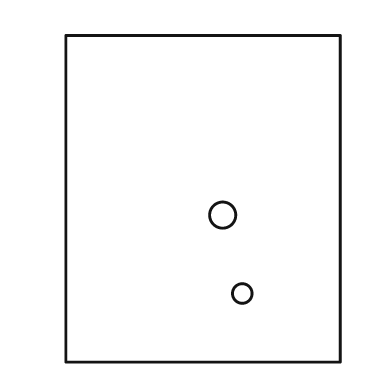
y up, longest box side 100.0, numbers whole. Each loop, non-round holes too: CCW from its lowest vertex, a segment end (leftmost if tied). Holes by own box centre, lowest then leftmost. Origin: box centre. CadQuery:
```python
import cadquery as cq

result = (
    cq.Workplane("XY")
    .moveTo(-42.0, -50.0)
    .lineTo(42.0, -50.0)
    .lineTo(42.0, 50.0)
    .lineTo(-42.0, 50.0)
    .close()
    .moveTo(12.0, -29.0)
    .circle(3.0)
    .moveTo(6.0, -5.0)
    .circle(4.0)
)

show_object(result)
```